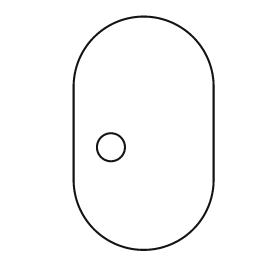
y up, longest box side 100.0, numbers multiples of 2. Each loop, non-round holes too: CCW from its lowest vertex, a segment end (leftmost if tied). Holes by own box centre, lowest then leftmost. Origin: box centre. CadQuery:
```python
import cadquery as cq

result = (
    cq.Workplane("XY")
    .moveTo(-30.0, -20.0)
    .threePointArc((0.0, -50.0), (30.0, -20.0))
    .lineTo(30.0, 20.0)
    .threePointArc((0.0, 50.0), (-30.0, 20.0))
    .close()
    .moveTo(-14.0, -6.0)
    .circle(6.0)
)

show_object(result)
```